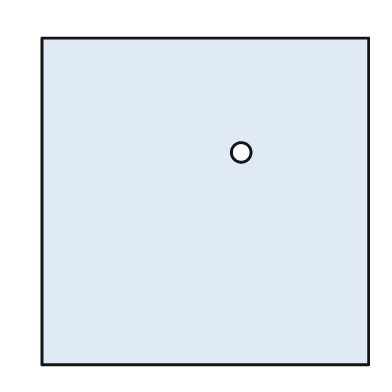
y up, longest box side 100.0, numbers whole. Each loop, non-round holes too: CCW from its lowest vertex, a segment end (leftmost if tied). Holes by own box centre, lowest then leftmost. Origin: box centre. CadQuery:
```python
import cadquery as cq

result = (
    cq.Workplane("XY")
    .moveTo(-50.0, -50.0)
    .lineTo(50.0, -50.0)
    .lineTo(50.0, 50.0)
    .lineTo(-50.0, 50.0)
    .close()
    .moveTo(11.0, 15.0)
    .circle(3.0)
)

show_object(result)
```